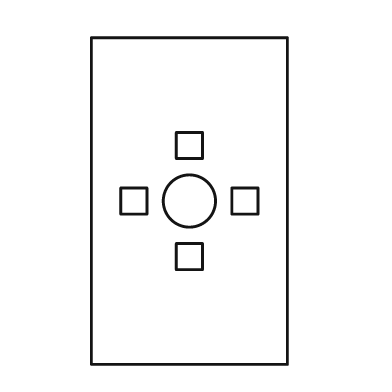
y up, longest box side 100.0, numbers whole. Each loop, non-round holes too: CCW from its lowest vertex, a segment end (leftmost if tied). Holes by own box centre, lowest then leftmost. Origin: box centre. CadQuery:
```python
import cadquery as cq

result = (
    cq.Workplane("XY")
    .moveTo(-30.0, -50.0)
    .lineTo(30.0, -50.0)
    .lineTo(30.0, 50.0)
    .lineTo(-30.0, 50.0)
    .close()
    .moveTo(-4.0, -21.0)
    .lineTo(4.0, -21.0)
    .lineTo(4.0, -13.0)
    .lineTo(-4.0, -13.0)
    .close()
    .moveTo(-21.0, -4.0)
    .lineTo(-13.0, -4.0)
    .lineTo(-13.0, 4.0)
    .lineTo(-21.0, 4.0)
    .close()
    .moveTo(0.0, 0.0)
    .circle(8.0)
    .moveTo(13.0, -4.0)
    .lineTo(21.0, -4.0)
    .lineTo(21.0, 4.0)
    .lineTo(13.0, 4.0)
    .close()
    .moveTo(-4.0, 13.0)
    .lineTo(4.0, 13.0)
    .lineTo(4.0, 21.0)
    .lineTo(-4.0, 21.0)
    .close()
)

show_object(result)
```